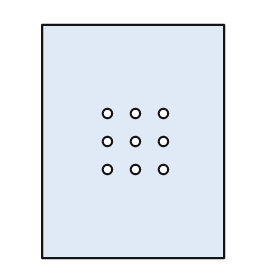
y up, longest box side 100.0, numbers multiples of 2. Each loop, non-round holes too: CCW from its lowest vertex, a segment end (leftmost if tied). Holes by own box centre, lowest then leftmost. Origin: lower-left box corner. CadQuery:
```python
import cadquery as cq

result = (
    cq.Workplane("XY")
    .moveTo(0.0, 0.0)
    .lineTo(78.0, 0.0)
    .lineTo(78.0, 100.0)
    .lineTo(0.0, 100.0)
    .close()
    .moveTo(28.0, 38.0)
    .circle(2.0)
    .moveTo(40.0, 38.0)
    .circle(2.0)
    .moveTo(52.0, 38.0)
    .circle(2.0)
    .moveTo(28.0, 50.0)
    .circle(2.0)
    .moveTo(40.0, 50.0)
    .circle(2.0)
    .moveTo(52.0, 50.0)
    .circle(2.0)
    .moveTo(28.0, 62.0)
    .circle(2.0)
    .moveTo(40.0, 62.0)
    .circle(2.0)
    .moveTo(52.0, 62.0)
    .circle(2.0)
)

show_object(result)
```